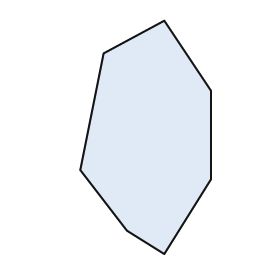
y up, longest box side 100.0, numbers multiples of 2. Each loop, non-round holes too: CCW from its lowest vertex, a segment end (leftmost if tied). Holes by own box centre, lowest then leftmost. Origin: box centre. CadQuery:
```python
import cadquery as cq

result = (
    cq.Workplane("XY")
    .moveTo(8.0, -50.0)
    .lineTo(28.0, -18.0)
    .lineTo(28.0, 20.0)
    .lineTo(8.0, 50.0)
    .lineTo(-18.0, 36.0)
    .lineTo(-28.0, -14.0)
    .lineTo(-8.0, -40.0)
    .close()
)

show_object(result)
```